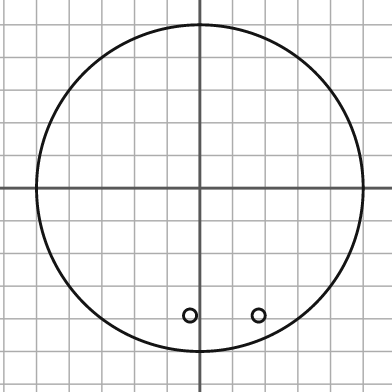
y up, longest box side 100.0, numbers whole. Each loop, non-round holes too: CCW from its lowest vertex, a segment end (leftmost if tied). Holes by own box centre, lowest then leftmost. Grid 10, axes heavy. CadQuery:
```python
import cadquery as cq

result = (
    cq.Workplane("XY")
    .moveTo(0.0, 0.0)
    .circle(50.0)
    .moveTo(-3.0, -39.0)
    .circle(2.0)
    .moveTo(18.0, -39.0)
    .circle(2.0)
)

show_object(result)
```